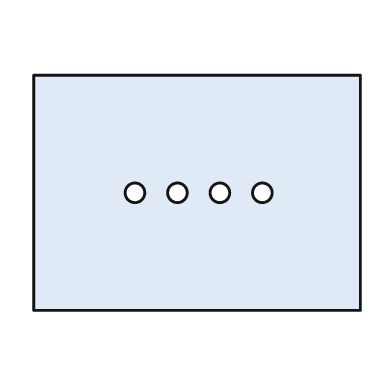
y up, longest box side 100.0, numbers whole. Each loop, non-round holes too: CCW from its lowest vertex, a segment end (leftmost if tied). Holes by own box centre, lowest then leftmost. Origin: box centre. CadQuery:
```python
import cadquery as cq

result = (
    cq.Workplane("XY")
    .moveTo(-50.0, -36.0)
    .lineTo(50.0, -36.0)
    .lineTo(50.0, 36.0)
    .lineTo(-50.0, 36.0)
    .close()
    .moveTo(-19.0, 0.0)
    .circle(3.0)
    .moveTo(-6.0, 0.0)
    .circle(3.0)
    .moveTo(7.0, 0.0)
    .circle(3.0)
    .moveTo(20.0, 0.0)
    .circle(3.0)
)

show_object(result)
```